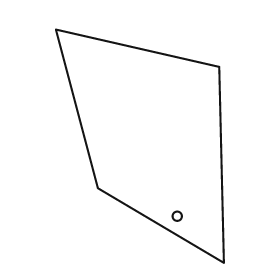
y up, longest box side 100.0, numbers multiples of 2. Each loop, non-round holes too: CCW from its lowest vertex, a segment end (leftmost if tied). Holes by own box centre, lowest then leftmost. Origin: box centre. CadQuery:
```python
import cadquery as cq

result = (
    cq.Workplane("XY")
    .moveTo(36.0, -50.0)
    .lineTo(34.0, 34.0)
    .lineTo(-36.0, 50.0)
    .lineTo(-18.0, -18.0)
    .close()
    .moveTo(16.0, -30.0)
    .circle(2.0)
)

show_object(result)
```